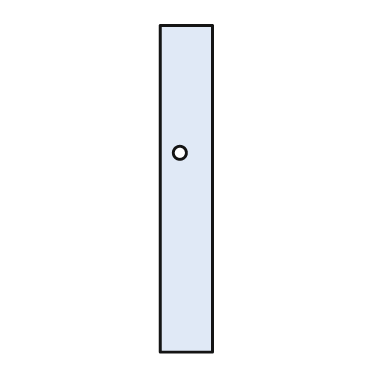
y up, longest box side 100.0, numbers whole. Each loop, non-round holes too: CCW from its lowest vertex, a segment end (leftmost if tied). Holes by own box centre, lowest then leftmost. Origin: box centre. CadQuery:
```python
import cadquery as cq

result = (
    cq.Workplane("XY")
    .moveTo(-8.0, -50.0)
    .lineTo(8.0, -50.0)
    .lineTo(8.0, 50.0)
    .lineTo(-8.0, 50.0)
    .close()
    .moveTo(-2.0, 11.0)
    .circle(2.0)
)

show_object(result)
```